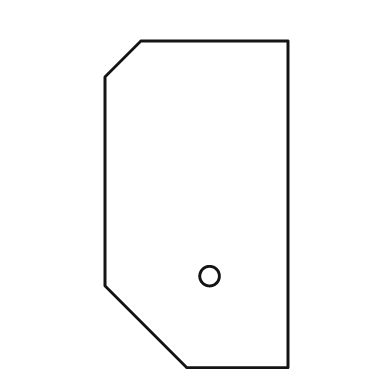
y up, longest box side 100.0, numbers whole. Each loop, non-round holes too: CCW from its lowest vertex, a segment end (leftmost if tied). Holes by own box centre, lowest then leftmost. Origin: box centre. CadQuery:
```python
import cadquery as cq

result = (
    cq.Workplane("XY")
    .moveTo(-3.0, -50.0)
    .lineTo(28.0, -50.0)
    .lineTo(28.0, 50.0)
    .lineTo(-17.0, 50.0)
    .lineTo(-28.0, 39.0)
    .lineTo(-28.0, -25.0)
    .close()
    .moveTo(4.0, -22.0)
    .circle(3.0)
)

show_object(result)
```